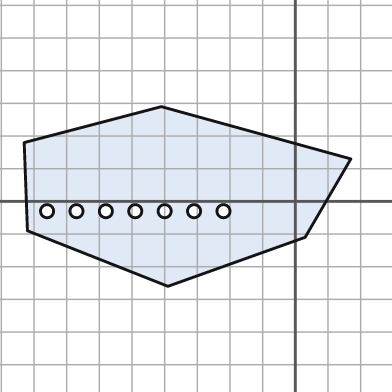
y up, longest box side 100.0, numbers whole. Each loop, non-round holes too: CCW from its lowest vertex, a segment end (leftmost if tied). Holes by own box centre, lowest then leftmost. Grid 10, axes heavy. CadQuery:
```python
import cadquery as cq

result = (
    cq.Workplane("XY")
    .moveTo(-39.0, -26.0)
    .lineTo(3.0, -11.0)
    .lineTo(17.0, 13.0)
    .lineTo(-41.0, 29.0)
    .lineTo(-83.0, 18.0)
    .lineTo(-82.0, -9.0)
    .close()
    .moveTo(-76.0, -3.0)
    .circle(2.0)
    .moveTo(-67.0, -3.0)
    .circle(2.0)
    .moveTo(-58.0, -3.0)
    .circle(2.0)
    .moveTo(-49.0, -3.0)
    .circle(2.0)
    .moveTo(-40.0, -3.0)
    .circle(2.0)
    .moveTo(-31.0, -3.0)
    .circle(2.0)
    .moveTo(-22.0, -3.0)
    .circle(2.0)
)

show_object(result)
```